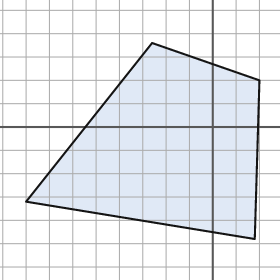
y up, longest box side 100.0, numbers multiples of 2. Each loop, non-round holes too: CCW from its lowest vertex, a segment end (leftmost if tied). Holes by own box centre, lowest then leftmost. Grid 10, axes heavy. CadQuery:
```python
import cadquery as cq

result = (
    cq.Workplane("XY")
    .moveTo(18.0, -48.0)
    .lineTo(20.0, 20.0)
    .lineTo(-26.0, 36.0)
    .lineTo(-80.0, -32.0)
    .close()
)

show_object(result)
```